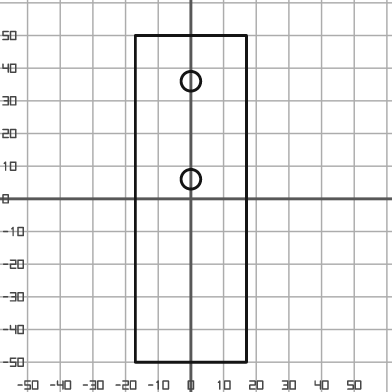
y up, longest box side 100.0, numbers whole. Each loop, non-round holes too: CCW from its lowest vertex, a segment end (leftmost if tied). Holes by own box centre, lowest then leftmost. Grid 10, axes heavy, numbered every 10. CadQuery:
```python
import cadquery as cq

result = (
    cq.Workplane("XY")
    .moveTo(-17.0, -50.0)
    .lineTo(17.0, -50.0)
    .lineTo(17.0, 50.0)
    .lineTo(-17.0, 50.0)
    .close()
    .moveTo(0.0, 6.0)
    .circle(3.0)
    .moveTo(0.0, 36.0)
    .circle(3.0)
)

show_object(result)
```